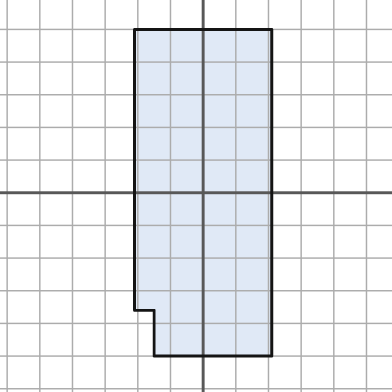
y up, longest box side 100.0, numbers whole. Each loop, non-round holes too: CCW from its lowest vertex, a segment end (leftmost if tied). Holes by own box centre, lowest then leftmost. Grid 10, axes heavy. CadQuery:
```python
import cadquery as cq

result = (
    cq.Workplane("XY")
    .moveTo(-15.0, -50.0)
    .lineTo(21.0, -50.0)
    .lineTo(21.0, 50.0)
    .lineTo(-21.0, 50.0)
    .lineTo(-21.0, -36.0)
    .lineTo(-15.0, -36.0)
    .close()
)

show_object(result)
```